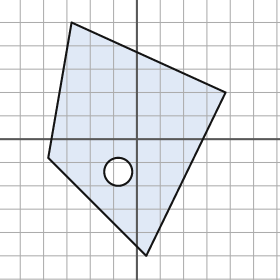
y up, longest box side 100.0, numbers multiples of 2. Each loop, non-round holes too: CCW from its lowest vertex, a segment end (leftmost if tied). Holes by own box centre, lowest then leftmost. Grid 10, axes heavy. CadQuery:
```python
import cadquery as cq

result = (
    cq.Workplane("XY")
    .moveTo(4.0, -50.0)
    .lineTo(38.0, 20.0)
    .lineTo(-28.0, 50.0)
    .lineTo(-38.0, -8.0)
    .close()
    .moveTo(-8.0, -14.0)
    .circle(6.0)
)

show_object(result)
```